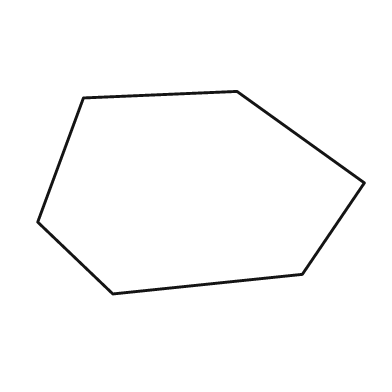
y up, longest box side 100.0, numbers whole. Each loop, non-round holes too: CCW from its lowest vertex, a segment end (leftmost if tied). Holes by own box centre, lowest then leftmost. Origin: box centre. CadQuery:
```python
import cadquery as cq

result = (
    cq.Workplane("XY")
    .moveTo(-27.0, -31.0)
    .lineTo(31.0, -25.0)
    .lineTo(50.0, 3.0)
    .lineTo(11.0, 31.0)
    .lineTo(-36.0, 29.0)
    .lineTo(-50.0, -9.0)
    .close()
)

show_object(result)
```